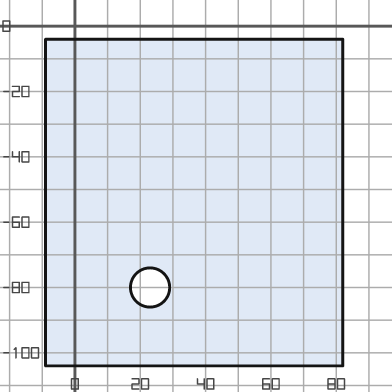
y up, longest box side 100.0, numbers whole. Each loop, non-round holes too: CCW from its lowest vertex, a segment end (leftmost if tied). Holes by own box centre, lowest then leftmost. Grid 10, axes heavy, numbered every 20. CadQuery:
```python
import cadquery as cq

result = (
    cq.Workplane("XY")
    .moveTo(-9.0, -104.0)
    .lineTo(82.0, -104.0)
    .lineTo(82.0, -4.0)
    .lineTo(-9.0, -4.0)
    .close()
    .moveTo(23.0, -80.0)
    .circle(6.0)
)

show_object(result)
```